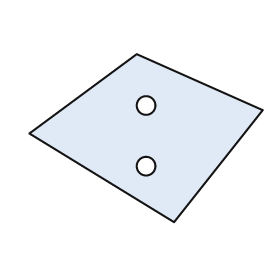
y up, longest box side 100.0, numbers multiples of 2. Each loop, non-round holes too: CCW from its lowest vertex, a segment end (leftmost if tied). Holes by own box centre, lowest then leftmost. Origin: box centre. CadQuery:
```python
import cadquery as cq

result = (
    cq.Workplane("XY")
    .moveTo(12.0, -36.0)
    .lineTo(50.0, 12.0)
    .lineTo(-4.0, 36.0)
    .lineTo(-50.0, 2.0)
    .close()
    .moveTo(0.0, -12.0)
    .circle(4.0)
    .moveTo(0.0, 14.0)
    .circle(4.0)
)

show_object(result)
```